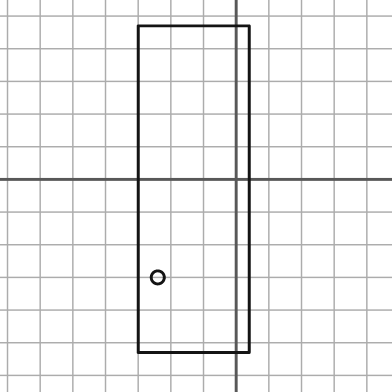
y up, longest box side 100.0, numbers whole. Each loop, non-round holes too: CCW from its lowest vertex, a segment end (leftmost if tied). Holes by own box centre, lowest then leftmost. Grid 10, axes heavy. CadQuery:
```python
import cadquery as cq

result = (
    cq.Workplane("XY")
    .moveTo(-30.0, -53.0)
    .lineTo(4.0, -53.0)
    .lineTo(4.0, 47.0)
    .lineTo(-30.0, 47.0)
    .close()
    .moveTo(-24.0, -30.0)
    .circle(2.0)
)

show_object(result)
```